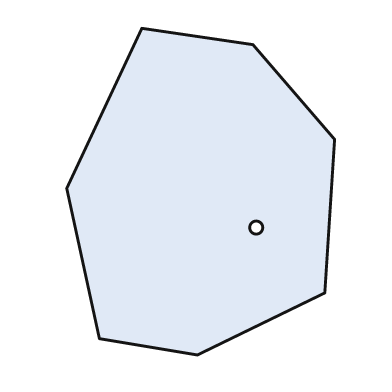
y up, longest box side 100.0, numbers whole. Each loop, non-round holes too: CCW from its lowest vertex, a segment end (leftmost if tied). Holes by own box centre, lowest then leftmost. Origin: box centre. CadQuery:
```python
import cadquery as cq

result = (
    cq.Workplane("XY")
    .moveTo(-1.0, -50.0)
    .lineTo(38.0, -31.0)
    .lineTo(41.0, 16.0)
    .lineTo(16.0, 45.0)
    .lineTo(-18.0, 50.0)
    .lineTo(-41.0, 1.0)
    .lineTo(-31.0, -45.0)
    .close()
    .moveTo(17.0, -11.0)
    .circle(2.0)
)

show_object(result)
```